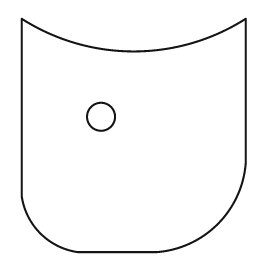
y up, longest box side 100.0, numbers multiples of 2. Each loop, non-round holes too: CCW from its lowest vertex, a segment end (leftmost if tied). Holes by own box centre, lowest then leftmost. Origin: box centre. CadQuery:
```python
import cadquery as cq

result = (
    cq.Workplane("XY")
    .moveTo(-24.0, -50.0)
    .lineTo(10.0, -50.0)
    .threePointArc((36.0, -38.0), (48.0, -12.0))
    .lineTo(48.0, 50.0)
    .threePointArc((0.0, 36.0), (-48.0, 50.0))
    .lineTo(-48.0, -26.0)
    .threePointArc((-40.0, -42.0), (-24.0, -50.0))
    .close()
    .moveTo(-14.0, 8.0)
    .circle(6.0)
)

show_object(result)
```